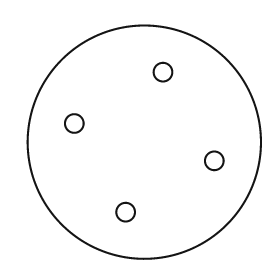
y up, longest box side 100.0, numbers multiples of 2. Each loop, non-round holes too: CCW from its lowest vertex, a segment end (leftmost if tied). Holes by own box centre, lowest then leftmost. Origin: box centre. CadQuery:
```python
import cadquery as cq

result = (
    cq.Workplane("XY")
    .moveTo(0.0, 0.0)
    .circle(50.0)
    .moveTo(-8.0, -30.0)
    .circle(4.0)
    .moveTo(30.0, -8.0)
    .circle(4.0)
    .moveTo(-30.0, 8.0)
    .circle(4.0)
    .moveTo(8.0, 30.0)
    .circle(4.0)
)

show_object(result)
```